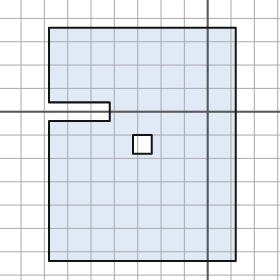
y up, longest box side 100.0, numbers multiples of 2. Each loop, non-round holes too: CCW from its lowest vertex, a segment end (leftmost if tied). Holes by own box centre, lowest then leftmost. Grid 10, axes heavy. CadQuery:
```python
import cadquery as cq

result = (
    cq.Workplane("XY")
    .moveTo(-68.0, -64.0)
    .lineTo(12.0, -64.0)
    .lineTo(12.0, 36.0)
    .lineTo(-68.0, 36.0)
    .lineTo(-68.0, 4.0)
    .lineTo(-42.0, 4.0)
    .lineTo(-42.0, -4.0)
    .lineTo(-68.0, -4.0)
    .close()
    .moveTo(-32.0, -18.0)
    .lineTo(-24.0, -18.0)
    .lineTo(-24.0, -10.0)
    .lineTo(-32.0, -10.0)
    .close()
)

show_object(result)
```